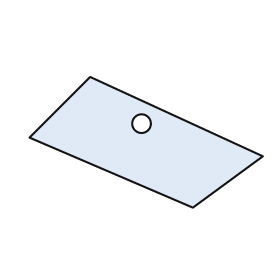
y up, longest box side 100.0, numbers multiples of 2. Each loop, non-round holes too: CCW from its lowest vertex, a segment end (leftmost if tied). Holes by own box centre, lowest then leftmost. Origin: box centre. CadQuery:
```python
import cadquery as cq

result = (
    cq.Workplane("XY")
    .moveTo(20.0, -28.0)
    .lineTo(50.0, -6.0)
    .lineTo(-24.0, 28.0)
    .lineTo(-50.0, 2.0)
    .close()
    .moveTo(-2.0, 8.0)
    .circle(4.0)
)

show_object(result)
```